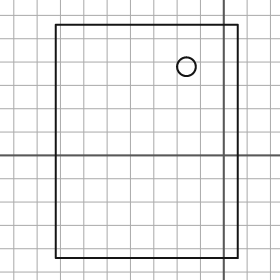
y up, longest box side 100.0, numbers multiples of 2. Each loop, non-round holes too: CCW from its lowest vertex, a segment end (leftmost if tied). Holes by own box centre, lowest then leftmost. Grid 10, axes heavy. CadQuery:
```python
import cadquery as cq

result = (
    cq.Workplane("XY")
    .moveTo(-72.0, -44.0)
    .lineTo(6.0, -44.0)
    .lineTo(6.0, 56.0)
    .lineTo(-72.0, 56.0)
    .close()
    .moveTo(-16.0, 38.0)
    .circle(4.0)
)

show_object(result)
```